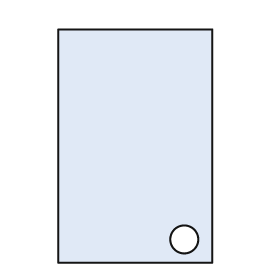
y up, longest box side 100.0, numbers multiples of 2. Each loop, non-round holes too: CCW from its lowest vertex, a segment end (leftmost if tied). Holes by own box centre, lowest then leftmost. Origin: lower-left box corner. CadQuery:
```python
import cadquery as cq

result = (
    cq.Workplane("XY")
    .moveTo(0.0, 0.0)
    .lineTo(66.0, 0.0)
    .lineTo(66.0, 100.0)
    .lineTo(0.0, 100.0)
    .close()
    .moveTo(54.0, 10.0)
    .circle(6.0)
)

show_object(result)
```